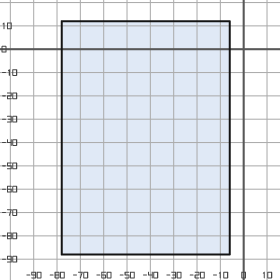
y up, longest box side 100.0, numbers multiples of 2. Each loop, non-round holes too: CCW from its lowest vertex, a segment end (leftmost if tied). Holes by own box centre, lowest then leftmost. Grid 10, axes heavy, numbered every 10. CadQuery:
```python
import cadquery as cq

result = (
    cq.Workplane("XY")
    .moveTo(-78.0, -88.0)
    .lineTo(-6.0, -88.0)
    .lineTo(-6.0, 12.0)
    .lineTo(-78.0, 12.0)
    .close()
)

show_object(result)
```